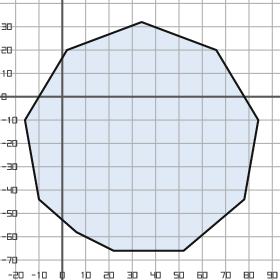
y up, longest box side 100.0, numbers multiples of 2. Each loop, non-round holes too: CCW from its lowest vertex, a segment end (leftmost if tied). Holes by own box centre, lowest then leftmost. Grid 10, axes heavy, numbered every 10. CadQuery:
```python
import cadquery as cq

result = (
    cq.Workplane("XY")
    .moveTo(22.0, -66.0)
    .lineTo(52.0, -66.0)
    .lineTo(78.0, -44.0)
    .lineTo(84.0, -10.0)
    .lineTo(66.0, 20.0)
    .lineTo(34.0, 32.0)
    .lineTo(2.0, 20.0)
    .lineTo(-16.0, -10.0)
    .lineTo(-10.0, -44.0)
    .lineTo(6.0, -58.0)
    .close()
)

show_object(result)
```